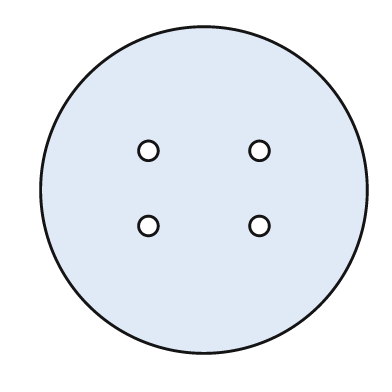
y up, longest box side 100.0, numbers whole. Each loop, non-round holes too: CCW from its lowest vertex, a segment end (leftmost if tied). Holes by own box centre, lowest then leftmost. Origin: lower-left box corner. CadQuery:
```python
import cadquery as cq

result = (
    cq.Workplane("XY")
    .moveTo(50.0, 50.0)
    .circle(50.0)
    .moveTo(33.0, 39.0)
    .circle(3.0)
    .moveTo(67.0, 39.0)
    .circle(3.0)
    .moveTo(33.0, 62.0)
    .circle(3.0)
    .moveTo(67.0, 62.0)
    .circle(3.0)
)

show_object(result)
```